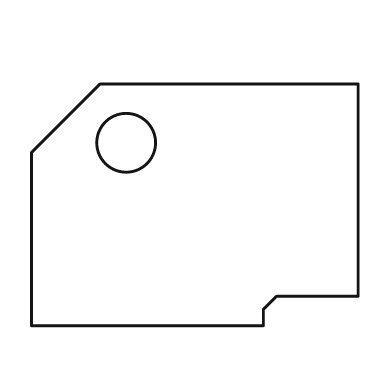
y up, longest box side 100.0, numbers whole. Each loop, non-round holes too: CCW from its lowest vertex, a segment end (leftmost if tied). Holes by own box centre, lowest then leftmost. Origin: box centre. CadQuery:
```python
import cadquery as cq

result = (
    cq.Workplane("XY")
    .moveTo(-50.0, -37.0)
    .lineTo(21.0, -37.0)
    .lineTo(21.0, -32.0)
    .lineTo(25.0, -28.0)
    .lineTo(50.0, -28.0)
    .lineTo(50.0, 37.0)
    .lineTo(-29.0, 37.0)
    .lineTo(-50.0, 16.0)
    .close()
    .moveTo(-21.0, 19.0)
    .circle(9.0)
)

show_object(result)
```